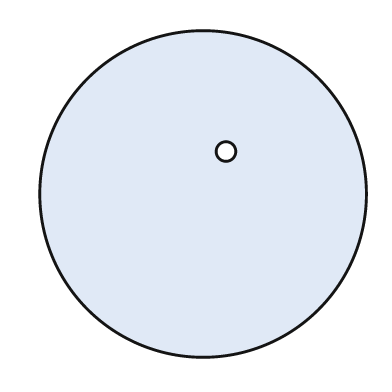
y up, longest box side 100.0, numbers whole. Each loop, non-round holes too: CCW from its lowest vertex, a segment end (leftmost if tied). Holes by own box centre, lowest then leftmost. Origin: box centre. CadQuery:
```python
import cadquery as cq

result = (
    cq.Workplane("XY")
    .moveTo(0.0, 0.0)
    .circle(50.0)
    .moveTo(7.0, 13.0)
    .circle(3.0)
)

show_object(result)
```